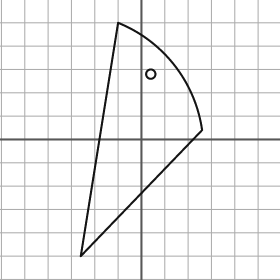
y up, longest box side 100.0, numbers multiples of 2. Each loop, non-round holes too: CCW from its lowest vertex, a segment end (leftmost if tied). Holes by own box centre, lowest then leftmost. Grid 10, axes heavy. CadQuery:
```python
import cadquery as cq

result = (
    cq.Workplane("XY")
    .moveTo(-26.0, -50.0)
    .lineTo(26.0, 4.0)
    .threePointArc((14.0, 32.0), (-10.0, 50.0))
    .close()
    .moveTo(4.0, 28.0)
    .circle(2.0)
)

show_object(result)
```